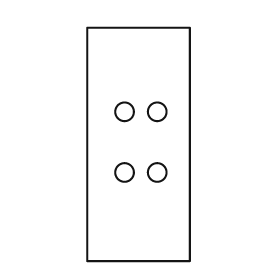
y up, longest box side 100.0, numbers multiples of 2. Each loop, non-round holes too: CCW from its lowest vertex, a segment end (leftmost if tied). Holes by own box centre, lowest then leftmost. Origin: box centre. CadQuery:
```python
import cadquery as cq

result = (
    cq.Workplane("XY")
    .moveTo(-22.0, -50.0)
    .lineTo(22.0, -50.0)
    .lineTo(22.0, 50.0)
    .lineTo(-22.0, 50.0)
    .close()
    .moveTo(-6.0, -12.0)
    .circle(4.0)
    .moveTo(8.0, -12.0)
    .circle(4.0)
    .moveTo(-6.0, 14.0)
    .circle(4.0)
    .moveTo(8.0, 14.0)
    .circle(4.0)
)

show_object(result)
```